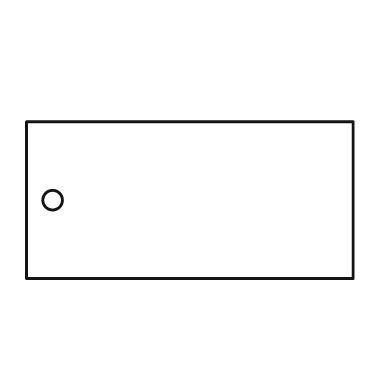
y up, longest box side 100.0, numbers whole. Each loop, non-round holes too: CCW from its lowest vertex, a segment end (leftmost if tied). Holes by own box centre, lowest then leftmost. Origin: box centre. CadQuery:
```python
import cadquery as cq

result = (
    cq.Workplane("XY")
    .moveTo(-50.0, -24.0)
    .lineTo(50.0, -24.0)
    .lineTo(50.0, 24.0)
    .lineTo(-50.0, 24.0)
    .close()
    .moveTo(-42.0, 0.0)
    .circle(3.0)
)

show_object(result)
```